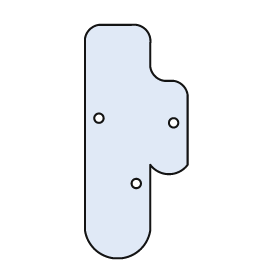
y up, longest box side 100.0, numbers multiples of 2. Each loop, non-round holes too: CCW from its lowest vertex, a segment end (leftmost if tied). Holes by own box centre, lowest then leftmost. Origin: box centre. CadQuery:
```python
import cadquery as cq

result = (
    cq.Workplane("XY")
    .moveTo(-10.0, -50.0)
    .lineTo(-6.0, -50.0)
    .threePointArc((2.0, -46.0), (6.0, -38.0))
    .lineTo(6.0, -10.0)
    .threePointArc((14.0, -14.0), (22.0, -10.0))
    .lineTo(22.0, 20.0)
    .threePointArc((20.0, 24.0), (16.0, 26.0))
    .lineTo(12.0, 26.0)
    .threePointArc((8.0, 28.0), (6.0, 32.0))
    .lineTo(6.0, 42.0)
    .threePointArc((4.0, 48.0), (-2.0, 50.0))
    .lineTo(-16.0, 50.0)
    .threePointArc((-20.0, 48.0), (-22.0, 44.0))
    .lineTo(-22.0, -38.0)
    .threePointArc((-18.0, -46.0), (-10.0, -50.0))
    .close()
    .moveTo(0.0, -18.0)
    .circle(2.0)
    .moveTo(16.0, 8.0)
    .circle(2.0)
    .moveTo(-16.0, 10.0)
    .circle(2.0)
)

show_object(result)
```